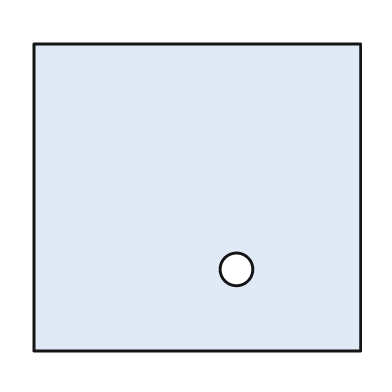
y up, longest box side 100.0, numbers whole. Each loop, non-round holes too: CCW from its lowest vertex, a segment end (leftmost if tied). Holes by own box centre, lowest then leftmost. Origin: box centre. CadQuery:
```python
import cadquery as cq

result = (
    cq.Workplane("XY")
    .moveTo(-50.0, -47.0)
    .lineTo(50.0, -47.0)
    .lineTo(50.0, 47.0)
    .lineTo(-50.0, 47.0)
    .close()
    .moveTo(12.0, -22.0)
    .circle(5.0)
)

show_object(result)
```